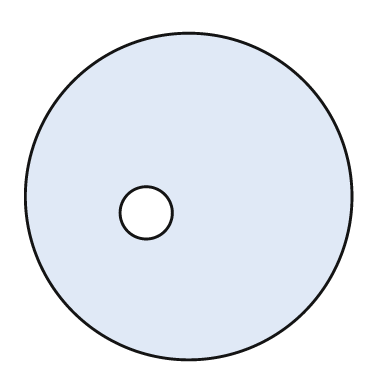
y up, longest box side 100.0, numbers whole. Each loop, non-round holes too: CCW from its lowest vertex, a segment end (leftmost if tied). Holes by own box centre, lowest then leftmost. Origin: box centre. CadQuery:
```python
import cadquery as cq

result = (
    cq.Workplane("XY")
    .moveTo(0.0, 0.0)
    .circle(50.0)
    .moveTo(-13.0, -5.0)
    .circle(8.0)
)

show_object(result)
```